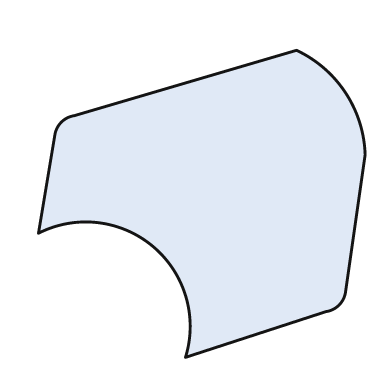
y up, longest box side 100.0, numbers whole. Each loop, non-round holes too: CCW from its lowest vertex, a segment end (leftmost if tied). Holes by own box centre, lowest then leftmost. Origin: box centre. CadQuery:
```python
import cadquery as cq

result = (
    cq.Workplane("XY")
    .moveTo(-5.0, -47.0)
    .lineTo(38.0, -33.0)
    .threePointArc((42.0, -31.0), (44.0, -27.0))
    .lineTo(50.0, 15.0)
    .threePointArc((44.0, 34.0), (29.0, 47.0))
    .lineTo(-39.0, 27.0)
    .threePointArc((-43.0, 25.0), (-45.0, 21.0))
    .lineTo(-50.0, -9.0)
    .threePointArc((-15.0, -13.0), (-5.0, -47.0))
    .close()
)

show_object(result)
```